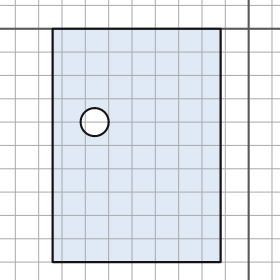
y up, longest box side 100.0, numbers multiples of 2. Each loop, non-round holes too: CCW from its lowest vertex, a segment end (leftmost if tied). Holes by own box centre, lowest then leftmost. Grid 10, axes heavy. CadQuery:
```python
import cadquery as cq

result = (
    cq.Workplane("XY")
    .moveTo(-84.0, -100.0)
    .lineTo(-12.0, -100.0)
    .lineTo(-12.0, 0.0)
    .lineTo(-84.0, 0.0)
    .close()
    .moveTo(-66.0, -40.0)
    .circle(6.0)
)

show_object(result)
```